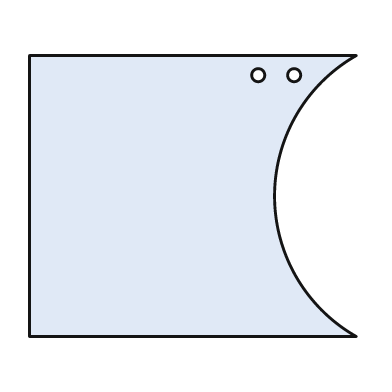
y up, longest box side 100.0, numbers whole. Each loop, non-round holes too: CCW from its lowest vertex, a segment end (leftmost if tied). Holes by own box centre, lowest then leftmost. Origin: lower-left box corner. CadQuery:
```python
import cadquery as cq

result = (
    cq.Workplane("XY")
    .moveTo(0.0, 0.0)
    .lineTo(100.0, 0.0)
    .threePointArc((75.0, 43.0), (100.0, 86.0))
    .lineTo(0.0, 86.0)
    .close()
    .moveTo(70.0, 80.0)
    .circle(2.0)
    .moveTo(81.0, 80.0)
    .circle(2.0)
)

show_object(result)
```